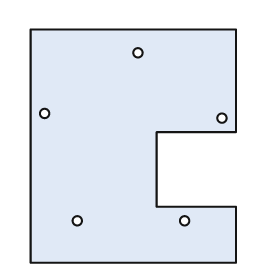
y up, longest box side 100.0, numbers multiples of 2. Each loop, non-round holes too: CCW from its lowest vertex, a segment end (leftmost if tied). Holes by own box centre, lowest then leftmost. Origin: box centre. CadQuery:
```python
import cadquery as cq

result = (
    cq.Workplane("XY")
    .moveTo(-44.0, -50.0)
    .lineTo(44.0, -50.0)
    .lineTo(44.0, -26.0)
    .lineTo(10.0, -26.0)
    .lineTo(10.0, 6.0)
    .lineTo(44.0, 6.0)
    .lineTo(44.0, 50.0)
    .lineTo(-44.0, 50.0)
    .close()
    .moveTo(-24.0, -32.0)
    .circle(2.0)
    .moveTo(22.0, -32.0)
    .circle(2.0)
    .moveTo(38.0, 12.0)
    .circle(2.0)
    .moveTo(-38.0, 14.0)
    .circle(2.0)
    .moveTo(2.0, 40.0)
    .circle(2.0)
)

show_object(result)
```